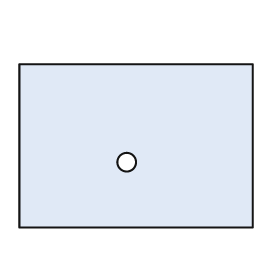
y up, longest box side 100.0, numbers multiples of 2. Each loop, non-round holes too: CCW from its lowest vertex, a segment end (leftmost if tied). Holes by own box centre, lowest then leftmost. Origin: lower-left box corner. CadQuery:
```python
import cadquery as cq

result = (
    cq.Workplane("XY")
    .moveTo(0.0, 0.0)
    .lineTo(100.0, 0.0)
    .lineTo(100.0, 70.0)
    .lineTo(0.0, 70.0)
    .close()
    .moveTo(46.0, 28.0)
    .circle(4.0)
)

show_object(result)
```